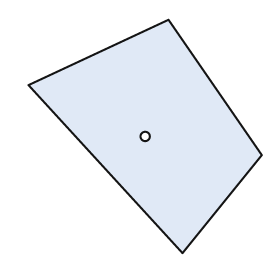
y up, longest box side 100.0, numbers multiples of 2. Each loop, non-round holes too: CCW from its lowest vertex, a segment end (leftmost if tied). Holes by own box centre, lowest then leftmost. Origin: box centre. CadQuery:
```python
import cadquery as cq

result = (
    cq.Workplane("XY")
    .moveTo(16.0, -50.0)
    .lineTo(50.0, -8.0)
    .lineTo(10.0, 50.0)
    .lineTo(-50.0, 22.0)
    .close()
    .moveTo(0.0, 0.0)
    .circle(2.0)
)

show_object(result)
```